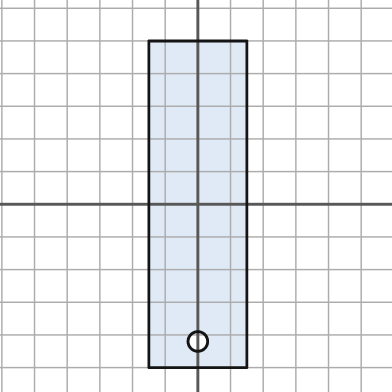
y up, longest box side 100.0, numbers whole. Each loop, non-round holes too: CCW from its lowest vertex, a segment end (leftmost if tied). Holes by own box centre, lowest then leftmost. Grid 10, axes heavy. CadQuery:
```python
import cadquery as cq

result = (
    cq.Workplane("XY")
    .moveTo(-15.0, -50.0)
    .lineTo(15.0, -50.0)
    .lineTo(15.0, 50.0)
    .lineTo(-15.0, 50.0)
    .close()
    .moveTo(0.0, -42.0)
    .circle(3.0)
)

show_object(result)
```